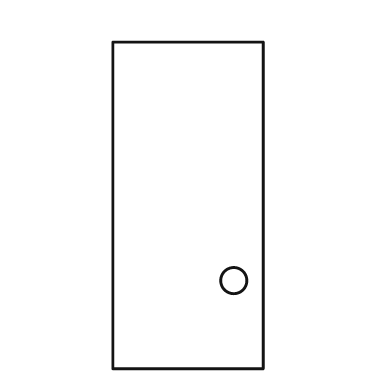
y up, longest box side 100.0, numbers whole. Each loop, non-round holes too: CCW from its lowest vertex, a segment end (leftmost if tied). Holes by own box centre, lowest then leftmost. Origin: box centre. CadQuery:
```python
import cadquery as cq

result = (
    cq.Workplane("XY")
    .moveTo(-23.0, -50.0)
    .lineTo(23.0, -50.0)
    .lineTo(23.0, 50.0)
    .lineTo(-23.0, 50.0)
    .close()
    .moveTo(14.0, -23.0)
    .circle(4.0)
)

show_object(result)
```